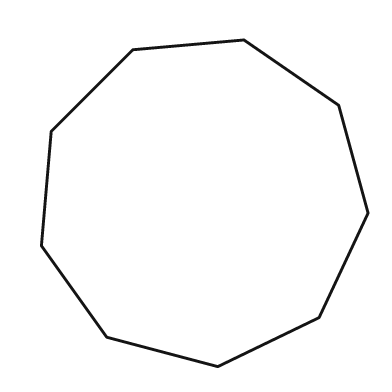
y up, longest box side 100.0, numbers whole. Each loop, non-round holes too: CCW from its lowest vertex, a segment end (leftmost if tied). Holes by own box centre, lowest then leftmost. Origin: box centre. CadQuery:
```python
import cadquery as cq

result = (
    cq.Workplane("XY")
    .moveTo(4.0, -50.0)
    .lineTo(35.0, -35.0)
    .lineTo(50.0, -3.0)
    .lineTo(41.0, 30.0)
    .lineTo(12.0, 50.0)
    .lineTo(-22.0, 47.0)
    .lineTo(-47.0, 22.0)
    .lineTo(-50.0, -13.0)
    .lineTo(-30.0, -41.0)
    .close()
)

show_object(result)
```